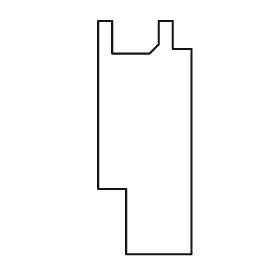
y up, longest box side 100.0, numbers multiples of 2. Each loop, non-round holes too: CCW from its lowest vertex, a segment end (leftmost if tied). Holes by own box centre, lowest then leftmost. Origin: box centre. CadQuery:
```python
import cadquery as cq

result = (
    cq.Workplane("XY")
    .moveTo(-8.0, -50.0)
    .lineTo(20.0, -50.0)
    .lineTo(20.0, 38.0)
    .lineTo(12.0, 38.0)
    .lineTo(12.0, 50.0)
    .lineTo(6.0, 50.0)
    .lineTo(6.0, 40.0)
    .lineTo(2.0, 36.0)
    .lineTo(-14.0, 36.0)
    .lineTo(-14.0, 50.0)
    .lineTo(-20.0, 50.0)
    .lineTo(-20.0, -22.0)
    .lineTo(-8.0, -22.0)
    .close()
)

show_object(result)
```